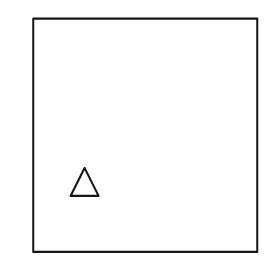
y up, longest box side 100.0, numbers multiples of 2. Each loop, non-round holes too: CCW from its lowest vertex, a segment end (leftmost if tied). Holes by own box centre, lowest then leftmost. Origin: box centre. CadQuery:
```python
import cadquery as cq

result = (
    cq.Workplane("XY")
    .moveTo(-48.0, -50.0)
    .lineTo(48.0, -50.0)
    .lineTo(48.0, 50.0)
    .lineTo(-48.0, 50.0)
    .close()
    .moveTo(-32.0, -26.0)
    .lineTo(-20.0, -26.0)
    .lineTo(-26.0, -14.0)
    .close()
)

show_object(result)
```